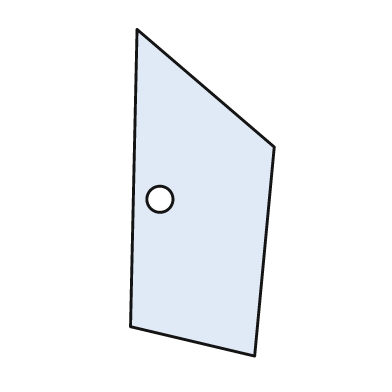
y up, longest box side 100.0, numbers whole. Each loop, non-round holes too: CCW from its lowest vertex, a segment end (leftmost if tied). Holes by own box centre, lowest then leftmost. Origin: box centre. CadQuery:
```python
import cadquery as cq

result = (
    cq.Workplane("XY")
    .moveTo(16.0, -50.0)
    .lineTo(22.0, 14.0)
    .lineTo(-20.0, 50.0)
    .lineTo(-22.0, -41.0)
    .close()
    .moveTo(-13.0, -2.0)
    .circle(4.0)
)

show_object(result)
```